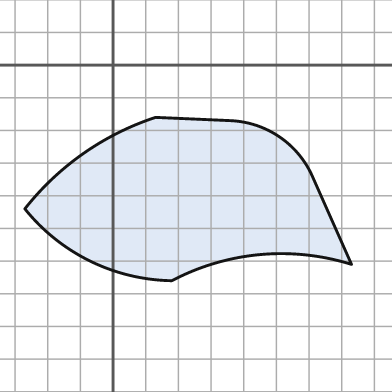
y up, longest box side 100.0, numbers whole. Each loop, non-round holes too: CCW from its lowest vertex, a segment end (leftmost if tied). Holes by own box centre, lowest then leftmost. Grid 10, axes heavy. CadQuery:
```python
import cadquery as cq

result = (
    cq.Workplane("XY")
    .moveTo(18.0, -66.0)
    .threePointArc((45.0, -58.0), (73.0, -61.0))
    .lineTo(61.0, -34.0)
    .threePointArc((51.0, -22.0), (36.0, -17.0))
    .lineTo(13.0, -16.0)
    .threePointArc((-9.0, -27.0), (-27.0, -44.0))
    .threePointArc((-7.0, -60.0), (18.0, -66.0))
    .close()
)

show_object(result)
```